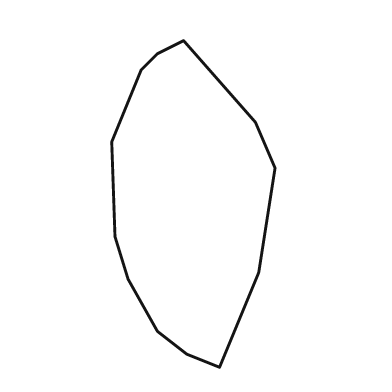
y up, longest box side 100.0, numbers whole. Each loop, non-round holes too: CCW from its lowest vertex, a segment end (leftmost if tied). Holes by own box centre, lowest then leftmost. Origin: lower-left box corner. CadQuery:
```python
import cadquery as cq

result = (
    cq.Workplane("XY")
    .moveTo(33.0, 0.0)
    .lineTo(45.0, 29.0)
    .lineTo(50.0, 61.0)
    .lineTo(44.0, 75.0)
    .lineTo(22.0, 100.0)
    .lineTo(14.0, 96.0)
    .lineTo(9.0, 91.0)
    .lineTo(0.0, 69.0)
    .lineTo(1.0, 40.0)
    .lineTo(5.0, 27.0)
    .lineTo(14.0, 11.0)
    .lineTo(23.0, 4.0)
    .close()
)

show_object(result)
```